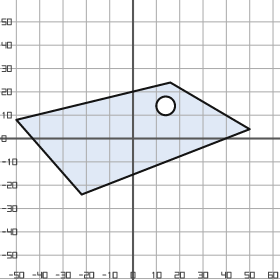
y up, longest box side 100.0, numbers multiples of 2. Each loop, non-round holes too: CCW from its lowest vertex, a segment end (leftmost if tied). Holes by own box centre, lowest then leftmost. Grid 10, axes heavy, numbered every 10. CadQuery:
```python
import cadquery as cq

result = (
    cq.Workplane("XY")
    .moveTo(-22.0, -24.0)
    .lineTo(50.0, 4.0)
    .lineTo(16.0, 24.0)
    .lineTo(-50.0, 8.0)
    .close()
    .moveTo(14.0, 14.0)
    .circle(4.0)
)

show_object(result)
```